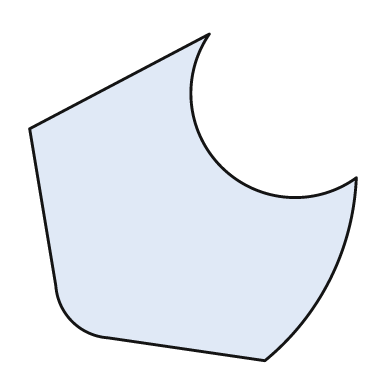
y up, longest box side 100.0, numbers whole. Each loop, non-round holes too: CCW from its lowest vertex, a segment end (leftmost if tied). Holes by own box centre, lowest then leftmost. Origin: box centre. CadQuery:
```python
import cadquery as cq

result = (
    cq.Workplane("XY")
    .moveTo(22.0, -50.0)
    .threePointArc((42.0, -25.0), (50.0, 6.0))
    .threePointArc((9.0, 9.0), (5.0, 50.0))
    .lineTo(-50.0, 21.0)
    .lineTo(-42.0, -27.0)
    .threePointArc((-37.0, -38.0), (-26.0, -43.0))
    .close()
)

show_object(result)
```